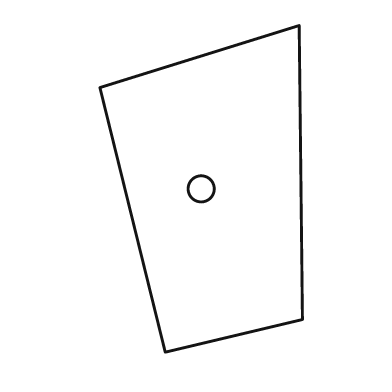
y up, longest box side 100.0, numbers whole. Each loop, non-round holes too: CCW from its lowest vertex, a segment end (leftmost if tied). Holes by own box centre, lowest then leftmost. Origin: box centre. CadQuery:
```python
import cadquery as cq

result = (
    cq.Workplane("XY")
    .moveTo(-11.0, -50.0)
    .lineTo(31.0, -40.0)
    .lineTo(30.0, 50.0)
    .lineTo(-31.0, 31.0)
    .close()
    .moveTo(0.0, 0.0)
    .circle(4.0)
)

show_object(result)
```